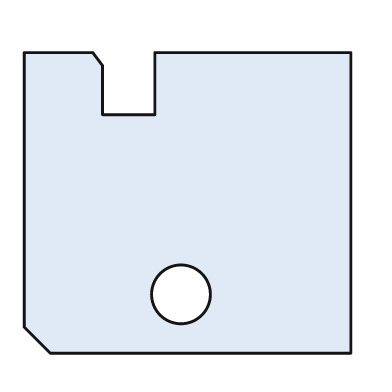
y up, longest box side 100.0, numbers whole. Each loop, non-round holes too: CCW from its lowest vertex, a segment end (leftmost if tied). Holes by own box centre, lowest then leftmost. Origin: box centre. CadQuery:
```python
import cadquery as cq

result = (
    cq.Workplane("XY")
    .moveTo(-42.0, -46.0)
    .lineTo(50.0, -46.0)
    .lineTo(50.0, 46.0)
    .lineTo(-10.0, 46.0)
    .lineTo(-10.0, 27.0)
    .lineTo(-26.0, 27.0)
    .lineTo(-26.0, 42.0)
    .lineTo(-29.0, 46.0)
    .lineTo(-50.0, 46.0)
    .lineTo(-50.0, -38.0)
    .close()
    .moveTo(-2.0, -28.0)
    .circle(9.0)
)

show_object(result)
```